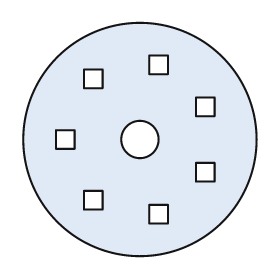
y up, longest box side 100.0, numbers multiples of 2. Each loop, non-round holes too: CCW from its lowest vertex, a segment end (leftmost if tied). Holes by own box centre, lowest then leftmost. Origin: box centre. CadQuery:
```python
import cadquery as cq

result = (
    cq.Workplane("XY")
    .moveTo(0.0, 0.0)
    .circle(50.0)
    .moveTo(4.0, -36.0)
    .lineTo(12.0, -36.0)
    .lineTo(12.0, -28.0)
    .lineTo(4.0, -28.0)
    .close()
    .moveTo(-24.0, -30.0)
    .lineTo(-16.0, -30.0)
    .lineTo(-16.0, -22.0)
    .lineTo(-24.0, -22.0)
    .close()
    .moveTo(24.0, -18.0)
    .lineTo(32.0, -18.0)
    .lineTo(32.0, -10.0)
    .lineTo(24.0, -10.0)
    .close()
    .moveTo(-36.0, -4.0)
    .lineTo(-28.0, -4.0)
    .lineTo(-28.0, 4.0)
    .lineTo(-36.0, 4.0)
    .close()
    .moveTo(0.0, 0.0)
    .circle(8.0)
    .moveTo(24.0, 10.0)
    .lineTo(32.0, 10.0)
    .lineTo(32.0, 18.0)
    .lineTo(24.0, 18.0)
    .close()
    .moveTo(-24.0, 22.0)
    .lineTo(-16.0, 22.0)
    .lineTo(-16.0, 30.0)
    .lineTo(-24.0, 30.0)
    .close()
    .moveTo(4.0, 28.0)
    .lineTo(12.0, 28.0)
    .lineTo(12.0, 36.0)
    .lineTo(4.0, 36.0)
    .close()
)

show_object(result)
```